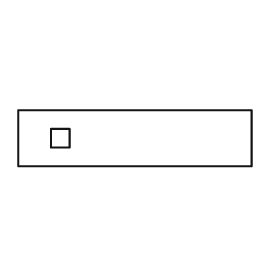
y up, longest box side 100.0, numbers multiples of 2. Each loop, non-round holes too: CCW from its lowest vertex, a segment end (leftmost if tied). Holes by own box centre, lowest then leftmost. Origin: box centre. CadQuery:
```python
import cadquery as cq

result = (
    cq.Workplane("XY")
    .moveTo(-50.0, -12.0)
    .lineTo(50.0, -12.0)
    .lineTo(50.0, 12.0)
    .lineTo(-50.0, 12.0)
    .close()
    .moveTo(-36.0, -4.0)
    .lineTo(-28.0, -4.0)
    .lineTo(-28.0, 4.0)
    .lineTo(-36.0, 4.0)
    .close()
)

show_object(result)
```